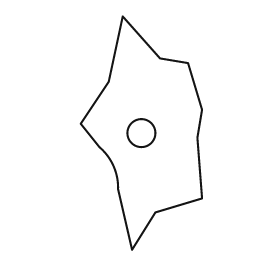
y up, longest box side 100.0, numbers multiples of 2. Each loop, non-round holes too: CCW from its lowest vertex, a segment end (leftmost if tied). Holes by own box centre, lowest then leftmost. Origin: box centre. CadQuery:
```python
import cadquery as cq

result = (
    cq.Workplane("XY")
    .moveTo(-4.0, -50.0)
    .lineTo(6.0, -34.0)
    .lineTo(26.0, -28.0)
    .lineTo(24.0, -2.0)
    .lineTo(26.0, 10.0)
    .lineTo(20.0, 30.0)
    .lineTo(8.0, 32.0)
    .lineTo(-8.0, 50.0)
    .lineTo(-14.0, 22.0)
    .lineTo(-26.0, 4.0)
    .lineTo(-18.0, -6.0)
    .threePointArc((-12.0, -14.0), (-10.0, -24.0))
    .close()
    .moveTo(0.0, 0.0)
    .circle(6.0)
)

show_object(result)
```